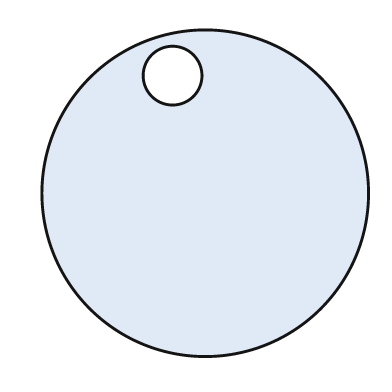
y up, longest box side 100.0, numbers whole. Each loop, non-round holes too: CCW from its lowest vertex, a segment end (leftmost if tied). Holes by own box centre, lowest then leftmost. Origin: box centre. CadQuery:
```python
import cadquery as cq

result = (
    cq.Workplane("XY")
    .moveTo(0.0, 0.0)
    .circle(50.0)
    .moveTo(-10.0, 36.0)
    .circle(9.0)
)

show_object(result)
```